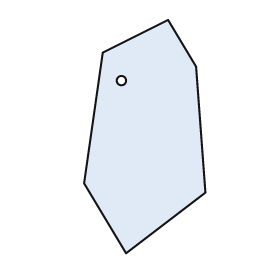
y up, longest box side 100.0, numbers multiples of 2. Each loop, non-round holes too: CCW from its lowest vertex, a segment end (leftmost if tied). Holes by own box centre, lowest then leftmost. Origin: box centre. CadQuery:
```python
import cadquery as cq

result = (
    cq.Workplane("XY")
    .moveTo(-8.0, -50.0)
    .lineTo(26.0, -24.0)
    .lineTo(22.0, 30.0)
    .lineTo(10.0, 50.0)
    .lineTo(-18.0, 36.0)
    .lineTo(-26.0, -20.0)
    .close()
    .moveTo(-10.0, 24.0)
    .circle(2.0)
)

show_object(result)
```